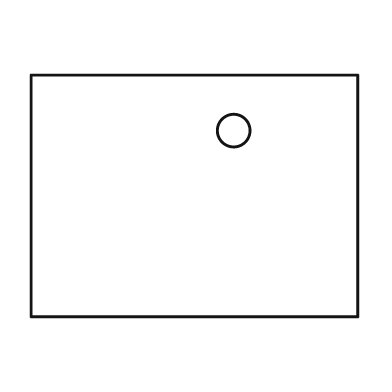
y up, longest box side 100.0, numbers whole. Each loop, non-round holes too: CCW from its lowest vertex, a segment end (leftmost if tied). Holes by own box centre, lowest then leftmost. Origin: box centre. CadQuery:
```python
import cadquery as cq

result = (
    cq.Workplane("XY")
    .moveTo(-50.0, -37.0)
    .lineTo(50.0, -37.0)
    .lineTo(50.0, 37.0)
    .lineTo(-50.0, 37.0)
    .close()
    .moveTo(12.0, 20.0)
    .circle(5.0)
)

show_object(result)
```